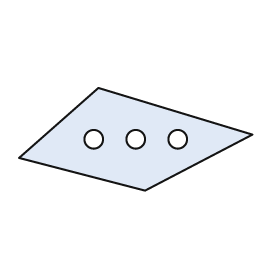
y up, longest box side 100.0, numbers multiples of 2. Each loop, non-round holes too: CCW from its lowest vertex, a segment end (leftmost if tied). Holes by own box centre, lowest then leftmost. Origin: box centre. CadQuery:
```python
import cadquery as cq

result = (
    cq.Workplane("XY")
    .moveTo(4.0, -22.0)
    .lineTo(50.0, 2.0)
    .lineTo(-16.0, 22.0)
    .lineTo(-50.0, -8.0)
    .close()
    .moveTo(-18.0, 0.0)
    .circle(4.0)
    .moveTo(0.0, 0.0)
    .circle(4.0)
    .moveTo(18.0, 0.0)
    .circle(4.0)
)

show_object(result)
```